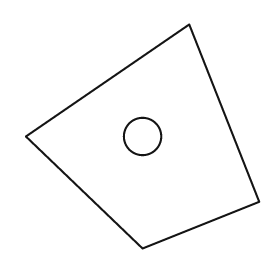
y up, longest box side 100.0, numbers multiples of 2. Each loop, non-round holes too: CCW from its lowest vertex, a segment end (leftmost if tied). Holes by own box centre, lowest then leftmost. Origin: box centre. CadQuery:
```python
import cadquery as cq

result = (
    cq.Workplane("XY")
    .moveTo(0.0, -48.0)
    .lineTo(50.0, -28.0)
    .lineTo(20.0, 48.0)
    .lineTo(-50.0, 0.0)
    .close()
    .moveTo(0.0, 0.0)
    .circle(8.0)
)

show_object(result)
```